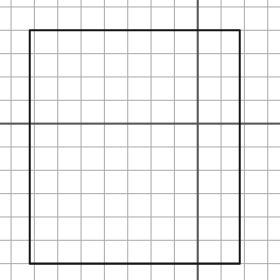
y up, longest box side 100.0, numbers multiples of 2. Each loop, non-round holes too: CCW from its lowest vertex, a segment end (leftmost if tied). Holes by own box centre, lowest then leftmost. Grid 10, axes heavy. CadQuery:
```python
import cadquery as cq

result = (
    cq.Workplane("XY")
    .moveTo(-72.0, -60.0)
    .lineTo(18.0, -60.0)
    .lineTo(18.0, 40.0)
    .lineTo(-72.0, 40.0)
    .close()
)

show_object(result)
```